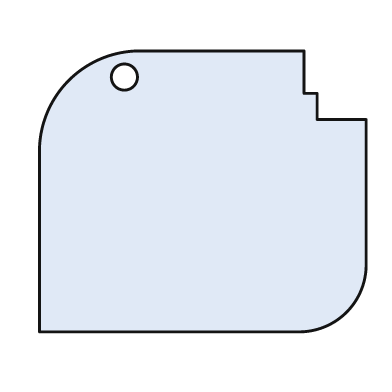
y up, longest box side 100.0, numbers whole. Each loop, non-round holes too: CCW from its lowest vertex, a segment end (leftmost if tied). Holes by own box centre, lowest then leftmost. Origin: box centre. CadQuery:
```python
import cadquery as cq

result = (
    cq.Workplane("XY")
    .moveTo(-50.0, -43.0)
    .lineTo(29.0, -43.0)
    .threePointArc((44.0, -37.0), (50.0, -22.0))
    .lineTo(50.0, 22.0)
    .lineTo(35.0, 22.0)
    .lineTo(35.0, 30.0)
    .lineTo(31.0, 30.0)
    .lineTo(31.0, 43.0)
    .lineTo(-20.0, 43.0)
    .threePointArc((-41.0, 34.0), (-50.0, 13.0))
    .close()
    .moveTo(-24.0, 35.0)
    .circle(4.0)
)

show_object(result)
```